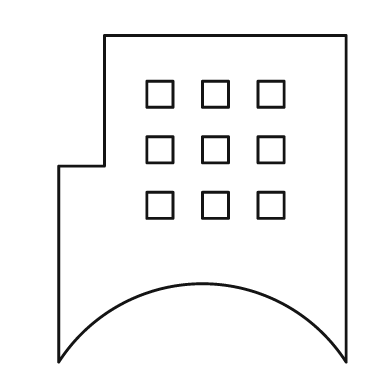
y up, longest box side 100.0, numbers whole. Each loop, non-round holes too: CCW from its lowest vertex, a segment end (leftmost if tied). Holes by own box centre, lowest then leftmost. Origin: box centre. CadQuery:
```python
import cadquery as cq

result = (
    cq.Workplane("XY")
    .moveTo(-44.0, -50.0)
    .threePointArc((0.0, -26.0), (44.0, -50.0))
    .lineTo(44.0, 50.0)
    .lineTo(-30.0, 50.0)
    .lineTo(-30.0, 10.0)
    .lineTo(-44.0, 10.0)
    .close()
    .moveTo(-17.0, -6.0)
    .lineTo(-9.0, -6.0)
    .lineTo(-9.0, 2.0)
    .lineTo(-17.0, 2.0)
    .close()
    .moveTo(0.0, -6.0)
    .lineTo(8.0, -6.0)
    .lineTo(8.0, 2.0)
    .lineTo(0.0, 2.0)
    .close()
    .moveTo(17.0, -6.0)
    .lineTo(25.0, -6.0)
    .lineTo(25.0, 2.0)
    .lineTo(17.0, 2.0)
    .close()
    .moveTo(-17.0, 11.0)
    .lineTo(-9.0, 11.0)
    .lineTo(-9.0, 19.0)
    .lineTo(-17.0, 19.0)
    .close()
    .moveTo(0.0, 11.0)
    .lineTo(8.0, 11.0)
    .lineTo(8.0, 19.0)
    .lineTo(0.0, 19.0)
    .close()
    .moveTo(17.0, 11.0)
    .lineTo(25.0, 11.0)
    .lineTo(25.0, 19.0)
    .lineTo(17.0, 19.0)
    .close()
    .moveTo(-17.0, 28.0)
    .lineTo(-9.0, 28.0)
    .lineTo(-9.0, 36.0)
    .lineTo(-17.0, 36.0)
    .close()
    .moveTo(0.0, 28.0)
    .lineTo(8.0, 28.0)
    .lineTo(8.0, 36.0)
    .lineTo(0.0, 36.0)
    .close()
    .moveTo(17.0, 28.0)
    .lineTo(25.0, 28.0)
    .lineTo(25.0, 36.0)
    .lineTo(17.0, 36.0)
    .close()
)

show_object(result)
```